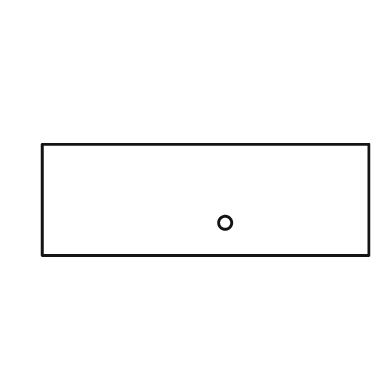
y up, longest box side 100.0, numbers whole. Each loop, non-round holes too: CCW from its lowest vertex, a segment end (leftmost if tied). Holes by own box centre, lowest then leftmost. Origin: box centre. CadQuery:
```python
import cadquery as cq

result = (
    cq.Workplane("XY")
    .moveTo(-50.0, -17.0)
    .lineTo(50.0, -17.0)
    .lineTo(50.0, 17.0)
    .lineTo(-50.0, 17.0)
    .close()
    .moveTo(6.0, -7.0)
    .circle(2.0)
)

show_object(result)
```